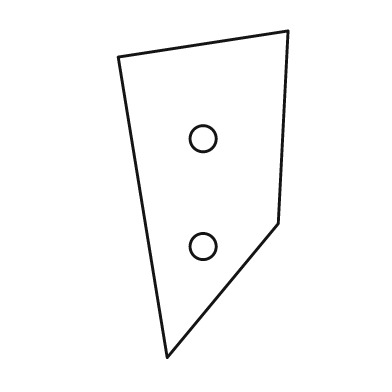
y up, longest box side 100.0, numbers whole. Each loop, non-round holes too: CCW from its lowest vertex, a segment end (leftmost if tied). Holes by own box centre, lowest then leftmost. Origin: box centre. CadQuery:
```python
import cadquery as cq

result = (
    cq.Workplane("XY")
    .moveTo(-11.0, -50.0)
    .lineTo(23.0, -9.0)
    .lineTo(26.0, 50.0)
    .lineTo(-26.0, 42.0)
    .close()
    .moveTo(0.0, -16.0)
    .circle(4.0)
    .moveTo(0.0, 17.0)
    .circle(4.0)
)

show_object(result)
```